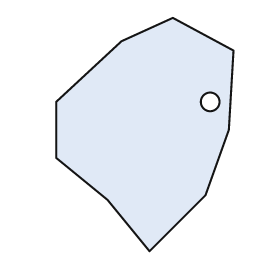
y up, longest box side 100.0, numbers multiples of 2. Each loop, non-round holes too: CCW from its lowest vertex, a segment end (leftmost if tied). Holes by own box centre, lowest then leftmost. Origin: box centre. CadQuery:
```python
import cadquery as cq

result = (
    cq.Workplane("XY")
    .moveTo(2.0, -50.0)
    .lineTo(26.0, -26.0)
    .lineTo(36.0, 2.0)
    .lineTo(38.0, 36.0)
    .lineTo(12.0, 50.0)
    .lineTo(-10.0, 40.0)
    .lineTo(-38.0, 14.0)
    .lineTo(-38.0, -10.0)
    .lineTo(-16.0, -28.0)
    .close()
    .moveTo(28.0, 14.0)
    .circle(4.0)
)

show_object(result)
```